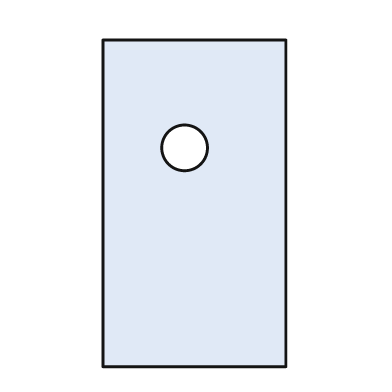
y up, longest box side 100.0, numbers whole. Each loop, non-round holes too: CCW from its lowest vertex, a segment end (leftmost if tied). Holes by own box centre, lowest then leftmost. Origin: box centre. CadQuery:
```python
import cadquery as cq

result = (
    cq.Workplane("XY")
    .moveTo(-28.0, -50.0)
    .lineTo(28.0, -50.0)
    .lineTo(28.0, 50.0)
    .lineTo(-28.0, 50.0)
    .close()
    .moveTo(-3.0, 17.0)
    .circle(7.0)
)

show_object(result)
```